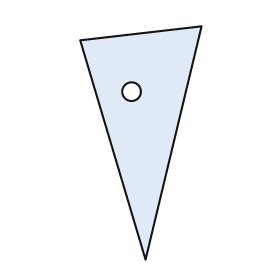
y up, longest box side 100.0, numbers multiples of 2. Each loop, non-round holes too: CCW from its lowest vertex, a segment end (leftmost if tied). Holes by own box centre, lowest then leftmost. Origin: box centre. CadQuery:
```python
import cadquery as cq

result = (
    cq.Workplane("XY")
    .moveTo(2.0, -50.0)
    .lineTo(26.0, 50.0)
    .lineTo(-26.0, 44.0)
    .close()
    .moveTo(-4.0, 22.0)
    .circle(4.0)
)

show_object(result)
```